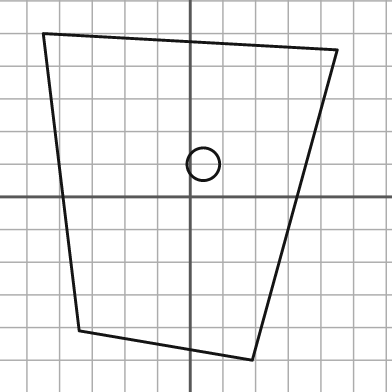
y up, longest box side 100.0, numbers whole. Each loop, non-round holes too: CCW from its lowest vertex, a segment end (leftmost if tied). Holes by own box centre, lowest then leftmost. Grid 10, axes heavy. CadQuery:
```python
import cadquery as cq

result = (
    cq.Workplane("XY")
    .moveTo(19.0, -50.0)
    .lineTo(45.0, 45.0)
    .lineTo(-45.0, 50.0)
    .lineTo(-34.0, -41.0)
    .close()
    .moveTo(4.0, 10.0)
    .circle(5.0)
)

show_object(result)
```